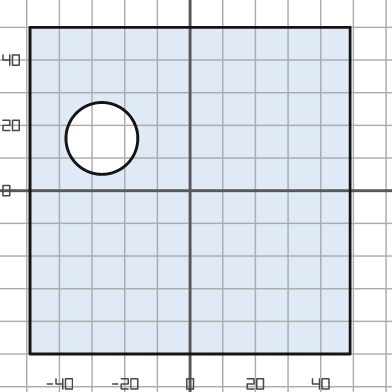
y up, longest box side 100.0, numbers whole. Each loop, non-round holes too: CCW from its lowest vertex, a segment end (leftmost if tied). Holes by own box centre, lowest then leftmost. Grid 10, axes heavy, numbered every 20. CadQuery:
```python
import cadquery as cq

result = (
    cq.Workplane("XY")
    .moveTo(-49.0, -50.0)
    .lineTo(49.0, -50.0)
    .lineTo(49.0, 50.0)
    .lineTo(-49.0, 50.0)
    .close()
    .moveTo(-27.0, 16.0)
    .circle(11.0)
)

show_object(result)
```